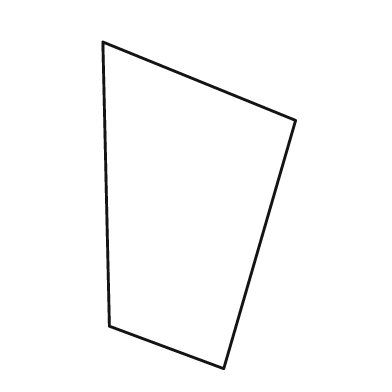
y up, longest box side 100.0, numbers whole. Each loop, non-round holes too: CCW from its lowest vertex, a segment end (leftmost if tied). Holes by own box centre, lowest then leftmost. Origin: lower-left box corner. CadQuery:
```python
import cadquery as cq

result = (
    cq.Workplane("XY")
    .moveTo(37.0, 0.0)
    .lineTo(59.0, 76.0)
    .lineTo(0.0, 100.0)
    .lineTo(2.0, 13.0)
    .close()
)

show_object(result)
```